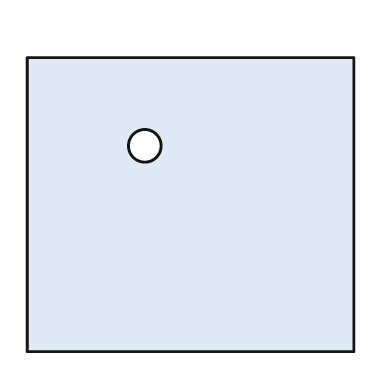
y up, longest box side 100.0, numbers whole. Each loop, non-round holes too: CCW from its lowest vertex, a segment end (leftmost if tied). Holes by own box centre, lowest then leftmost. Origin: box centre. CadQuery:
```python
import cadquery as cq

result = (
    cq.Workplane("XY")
    .moveTo(-50.0, -45.0)
    .lineTo(50.0, -45.0)
    .lineTo(50.0, 45.0)
    .lineTo(-50.0, 45.0)
    .close()
    .moveTo(-14.0, 18.0)
    .circle(5.0)
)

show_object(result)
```